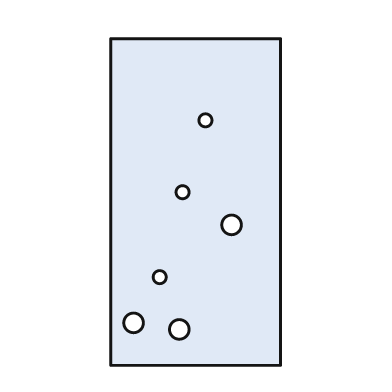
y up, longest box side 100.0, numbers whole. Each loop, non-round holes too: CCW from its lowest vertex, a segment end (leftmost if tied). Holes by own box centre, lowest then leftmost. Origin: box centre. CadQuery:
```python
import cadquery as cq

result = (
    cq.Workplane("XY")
    .moveTo(-26.0, -50.0)
    .lineTo(26.0, -50.0)
    .lineTo(26.0, 50.0)
    .lineTo(-26.0, 50.0)
    .close()
    .moveTo(-5.0, -39.0)
    .circle(3.0)
    .moveTo(-19.0, -37.0)
    .circle(3.0)
    .moveTo(-11.0, -23.0)
    .circle(2.0)
    .moveTo(11.0, -7.0)
    .circle(3.0)
    .moveTo(-4.0, 3.0)
    .circle(2.0)
    .moveTo(3.0, 25.0)
    .circle(2.0)
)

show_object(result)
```